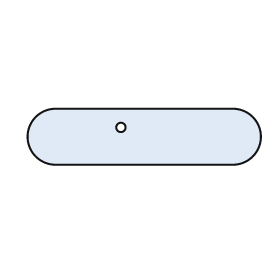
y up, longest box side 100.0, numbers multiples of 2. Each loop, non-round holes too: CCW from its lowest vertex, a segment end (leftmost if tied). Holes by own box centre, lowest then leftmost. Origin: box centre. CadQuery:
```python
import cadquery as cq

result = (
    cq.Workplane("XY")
    .moveTo(-38.0, -12.0)
    .lineTo(38.0, -12.0)
    .threePointArc((50.0, 0.0), (38.0, 12.0))
    .lineTo(-38.0, 12.0)
    .threePointArc((-50.0, 0.0), (-38.0, -12.0))
    .close()
    .moveTo(-10.0, 4.0)
    .circle(2.0)
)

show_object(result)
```